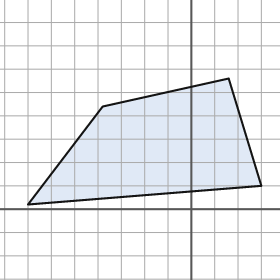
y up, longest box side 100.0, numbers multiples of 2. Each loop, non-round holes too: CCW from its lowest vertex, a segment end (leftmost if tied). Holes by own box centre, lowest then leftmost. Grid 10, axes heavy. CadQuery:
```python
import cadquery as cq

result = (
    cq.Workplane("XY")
    .moveTo(-70.0, 2.0)
    .lineTo(30.0, 10.0)
    .lineTo(16.0, 56.0)
    .lineTo(-38.0, 44.0)
    .close()
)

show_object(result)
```